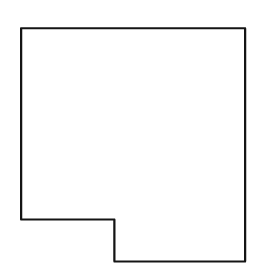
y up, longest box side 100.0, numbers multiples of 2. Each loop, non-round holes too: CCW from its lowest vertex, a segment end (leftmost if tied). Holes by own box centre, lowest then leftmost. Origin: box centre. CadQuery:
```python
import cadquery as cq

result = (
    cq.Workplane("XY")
    .moveTo(-8.0, -50.0)
    .lineTo(48.0, -50.0)
    .lineTo(48.0, 50.0)
    .lineTo(-48.0, 50.0)
    .lineTo(-48.0, -32.0)
    .lineTo(-8.0, -32.0)
    .close()
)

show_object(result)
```